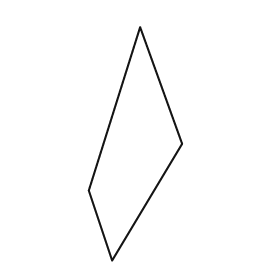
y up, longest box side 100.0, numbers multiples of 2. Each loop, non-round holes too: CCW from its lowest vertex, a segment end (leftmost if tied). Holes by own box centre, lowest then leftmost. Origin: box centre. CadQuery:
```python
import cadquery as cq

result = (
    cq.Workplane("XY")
    .moveTo(-10.0, -50.0)
    .lineTo(20.0, 0.0)
    .lineTo(2.0, 50.0)
    .lineTo(-20.0, -20.0)
    .close()
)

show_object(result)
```